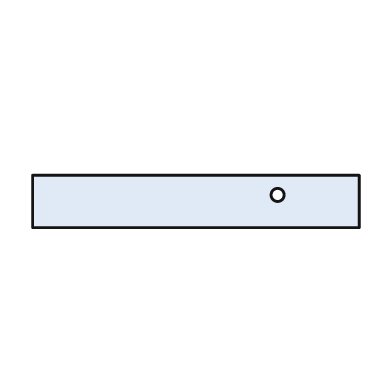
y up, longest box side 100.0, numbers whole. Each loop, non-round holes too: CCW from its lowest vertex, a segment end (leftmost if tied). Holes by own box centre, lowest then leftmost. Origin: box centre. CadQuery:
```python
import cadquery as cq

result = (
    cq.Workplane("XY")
    .moveTo(-50.0, -8.0)
    .lineTo(50.0, -8.0)
    .lineTo(50.0, 8.0)
    .lineTo(-50.0, 8.0)
    .close()
    .moveTo(25.0, 2.0)
    .circle(2.0)
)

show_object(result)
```